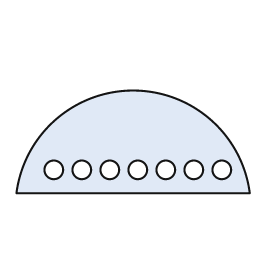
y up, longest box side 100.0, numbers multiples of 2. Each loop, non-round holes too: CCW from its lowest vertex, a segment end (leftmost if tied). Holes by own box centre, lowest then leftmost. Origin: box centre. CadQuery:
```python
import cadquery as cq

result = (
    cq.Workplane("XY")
    .moveTo(-50.0, -22.0)
    .lineTo(50.0, -22.0)
    .threePointArc((0.0, 22.0), (-50.0, -22.0))
    .close()
    .moveTo(-34.0, -12.0)
    .circle(4.0)
    .moveTo(-22.0, -12.0)
    .circle(4.0)
    .moveTo(-10.0, -12.0)
    .circle(4.0)
    .moveTo(2.0, -12.0)
    .circle(4.0)
    .moveTo(14.0, -12.0)
    .circle(4.0)
    .moveTo(26.0, -12.0)
    .circle(4.0)
    .moveTo(38.0, -12.0)
    .circle(4.0)
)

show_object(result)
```